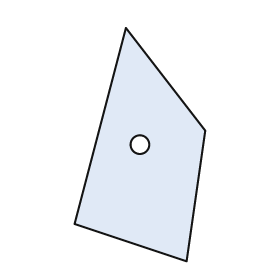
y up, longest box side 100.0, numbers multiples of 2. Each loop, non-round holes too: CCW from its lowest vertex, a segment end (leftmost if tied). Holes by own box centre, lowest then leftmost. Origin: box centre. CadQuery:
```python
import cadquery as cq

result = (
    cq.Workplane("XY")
    .moveTo(20.0, -50.0)
    .lineTo(28.0, 6.0)
    .lineTo(-6.0, 50.0)
    .lineTo(-28.0, -34.0)
    .close()
    .moveTo(0.0, 0.0)
    .circle(4.0)
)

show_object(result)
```